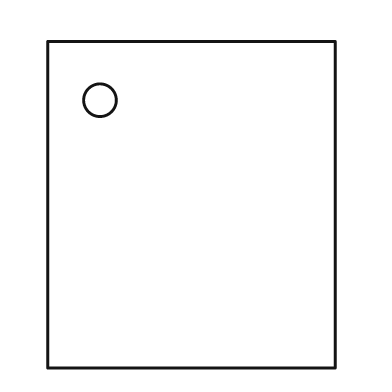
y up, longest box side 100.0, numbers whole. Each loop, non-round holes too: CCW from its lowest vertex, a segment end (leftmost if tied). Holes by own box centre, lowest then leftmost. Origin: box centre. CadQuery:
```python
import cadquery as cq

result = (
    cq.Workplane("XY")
    .moveTo(-44.0, -50.0)
    .lineTo(44.0, -50.0)
    .lineTo(44.0, 50.0)
    .lineTo(-44.0, 50.0)
    .close()
    .moveTo(-28.0, 32.0)
    .circle(5.0)
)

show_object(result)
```